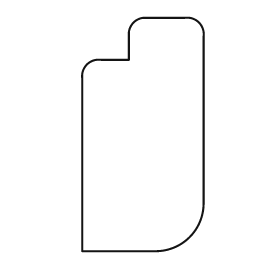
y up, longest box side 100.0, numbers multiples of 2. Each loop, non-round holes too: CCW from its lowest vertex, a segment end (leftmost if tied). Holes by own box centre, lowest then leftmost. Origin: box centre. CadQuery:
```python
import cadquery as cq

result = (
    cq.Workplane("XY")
    .moveTo(-26.0, -50.0)
    .lineTo(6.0, -50.0)
    .threePointArc((20.0, -44.0), (26.0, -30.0))
    .lineTo(26.0, 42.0)
    .threePointArc((24.0, 48.0), (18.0, 50.0))
    .lineTo(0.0, 50.0)
    .threePointArc((-4.0, 48.0), (-6.0, 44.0))
    .lineTo(-6.0, 32.0)
    .lineTo(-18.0, 32.0)
    .threePointArc((-24.0, 30.0), (-26.0, 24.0))
    .close()
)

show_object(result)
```